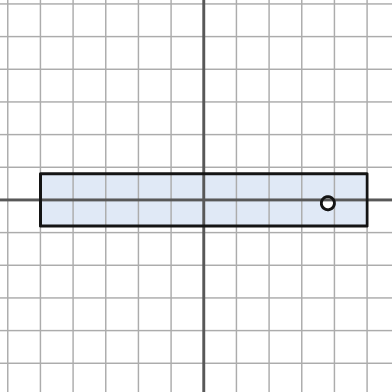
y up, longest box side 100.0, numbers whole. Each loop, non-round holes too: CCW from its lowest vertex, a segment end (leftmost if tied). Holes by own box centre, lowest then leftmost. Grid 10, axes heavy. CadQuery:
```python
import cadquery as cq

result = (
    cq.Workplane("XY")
    .moveTo(-50.0, -8.0)
    .lineTo(50.0, -8.0)
    .lineTo(50.0, 8.0)
    .lineTo(-50.0, 8.0)
    .close()
    .moveTo(38.0, -1.0)
    .circle(2.0)
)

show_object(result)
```